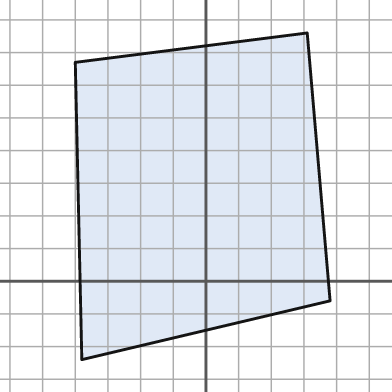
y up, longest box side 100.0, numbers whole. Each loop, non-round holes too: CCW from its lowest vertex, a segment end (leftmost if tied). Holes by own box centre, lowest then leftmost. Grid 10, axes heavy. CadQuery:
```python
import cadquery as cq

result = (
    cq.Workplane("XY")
    .moveTo(-38.0, -24.0)
    .lineTo(38.0, -6.0)
    .lineTo(31.0, 76.0)
    .lineTo(-40.0, 67.0)
    .close()
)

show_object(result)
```